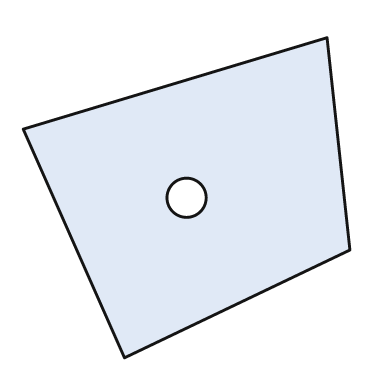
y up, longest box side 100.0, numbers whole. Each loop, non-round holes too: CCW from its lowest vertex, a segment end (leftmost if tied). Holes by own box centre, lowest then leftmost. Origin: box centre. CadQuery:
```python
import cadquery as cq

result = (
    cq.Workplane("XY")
    .moveTo(-19.0, -49.0)
    .lineTo(50.0, -16.0)
    .lineTo(43.0, 49.0)
    .lineTo(-50.0, 21.0)
    .close()
    .moveTo(0.0, 0.0)
    .circle(6.0)
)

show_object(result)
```